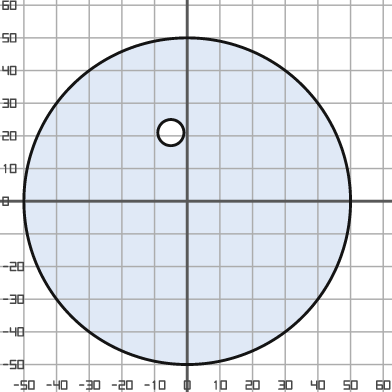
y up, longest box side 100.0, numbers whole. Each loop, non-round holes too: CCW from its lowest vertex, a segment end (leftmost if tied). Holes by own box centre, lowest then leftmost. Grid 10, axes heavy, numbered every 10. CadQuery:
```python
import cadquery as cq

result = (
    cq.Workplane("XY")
    .moveTo(0.0, 0.0)
    .circle(50.0)
    .moveTo(-5.0, 21.0)
    .circle(4.0)
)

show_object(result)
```